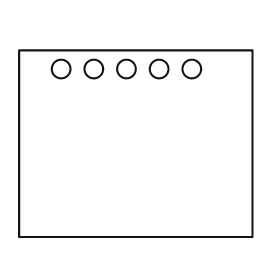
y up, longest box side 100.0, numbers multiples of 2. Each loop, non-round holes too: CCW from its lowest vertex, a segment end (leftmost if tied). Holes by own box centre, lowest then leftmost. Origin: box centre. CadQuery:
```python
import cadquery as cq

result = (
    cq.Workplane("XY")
    .moveTo(-50.0, -40.0)
    .lineTo(50.0, -40.0)
    .lineTo(50.0, 40.0)
    .lineTo(-50.0, 40.0)
    .close()
    .moveTo(-32.0, 32.0)
    .circle(4.0)
    .moveTo(-18.0, 32.0)
    .circle(4.0)
    .moveTo(-4.0, 32.0)
    .circle(4.0)
    .moveTo(10.0, 32.0)
    .circle(4.0)
    .moveTo(24.0, 32.0)
    .circle(4.0)
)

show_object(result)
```